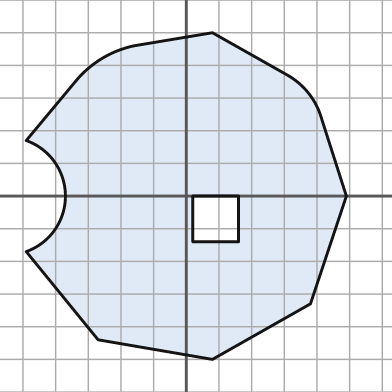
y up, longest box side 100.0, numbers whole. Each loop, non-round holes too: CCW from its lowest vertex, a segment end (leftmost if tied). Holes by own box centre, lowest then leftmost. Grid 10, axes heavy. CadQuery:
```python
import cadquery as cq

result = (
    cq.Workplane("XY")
    .moveTo(8.0, -50.0)
    .lineTo(38.0, -33.0)
    .lineTo(49.0, 0.0)
    .lineTo(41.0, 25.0)
    .threePointArc((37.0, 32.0), (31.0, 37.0))
    .lineTo(8.0, 50.0)
    .lineTo(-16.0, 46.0)
    .threePointArc((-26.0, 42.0), (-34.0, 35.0))
    .lineTo(-49.0, 17.0)
    .threePointArc((-37.0, 0.0), (-49.0, -17.0))
    .lineTo(-27.0, -44.0)
    .close()
    .moveTo(2.0, -14.0)
    .lineTo(16.0, -14.0)
    .lineTo(16.0, 0.0)
    .lineTo(2.0, 0.0)
    .close()
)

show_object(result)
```